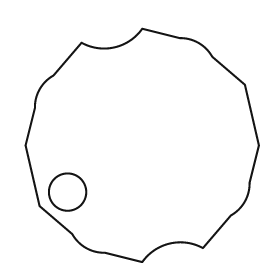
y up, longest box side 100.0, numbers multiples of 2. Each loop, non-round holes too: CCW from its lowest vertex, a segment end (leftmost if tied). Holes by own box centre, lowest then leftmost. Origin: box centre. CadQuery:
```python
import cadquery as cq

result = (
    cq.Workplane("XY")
    .moveTo(0.0, -50.0)
    .threePointArc((12.0, -42.0), (26.0, -44.0))
    .lineTo(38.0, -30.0)
    .threePointArc((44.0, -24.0), (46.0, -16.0))
    .lineTo(50.0, 0.0)
    .lineTo(44.0, 26.0)
    .lineTo(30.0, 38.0)
    .threePointArc((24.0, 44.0), (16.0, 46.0))
    .lineTo(0.0, 50.0)
    .threePointArc((-12.0, 42.0), (-26.0, 44.0))
    .lineTo(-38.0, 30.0)
    .threePointArc((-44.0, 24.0), (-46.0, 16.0))
    .lineTo(-50.0, 0.0)
    .lineTo(-44.0, -26.0)
    .lineTo(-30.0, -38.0)
    .threePointArc((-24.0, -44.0), (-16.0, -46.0))
    .close()
    .moveTo(-32.0, -20.0)
    .circle(8.0)
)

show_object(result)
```